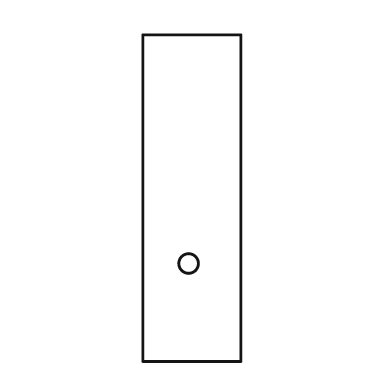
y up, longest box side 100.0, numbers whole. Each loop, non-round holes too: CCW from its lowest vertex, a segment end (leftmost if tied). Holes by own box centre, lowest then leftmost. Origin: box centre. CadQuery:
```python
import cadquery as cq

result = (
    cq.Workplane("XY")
    .moveTo(-15.0, -50.0)
    .lineTo(15.0, -50.0)
    .lineTo(15.0, 50.0)
    .lineTo(-15.0, 50.0)
    .close()
    .moveTo(-1.0, -20.0)
    .circle(3.0)
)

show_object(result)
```